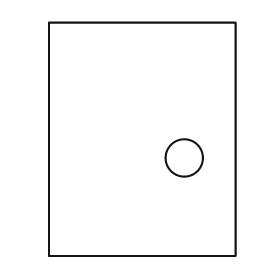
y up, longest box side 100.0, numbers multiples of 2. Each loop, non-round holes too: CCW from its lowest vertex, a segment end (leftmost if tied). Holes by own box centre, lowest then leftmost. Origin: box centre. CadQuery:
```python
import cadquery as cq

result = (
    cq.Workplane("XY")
    .moveTo(-40.0, -50.0)
    .lineTo(40.0, -50.0)
    .lineTo(40.0, 50.0)
    .lineTo(-40.0, 50.0)
    .close()
    .moveTo(18.0, -8.0)
    .circle(8.0)
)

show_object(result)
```